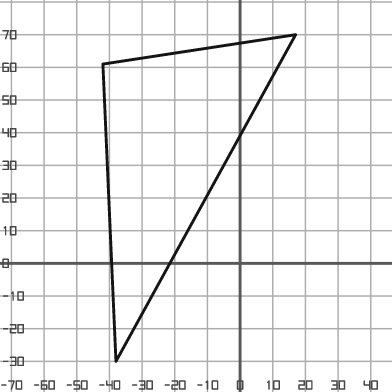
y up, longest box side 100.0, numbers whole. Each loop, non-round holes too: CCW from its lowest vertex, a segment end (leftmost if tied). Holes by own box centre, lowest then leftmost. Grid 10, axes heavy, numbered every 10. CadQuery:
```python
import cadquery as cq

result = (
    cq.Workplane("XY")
    .moveTo(-38.0, -30.0)
    .lineTo(17.0, 70.0)
    .lineTo(-42.0, 61.0)
    .close()
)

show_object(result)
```